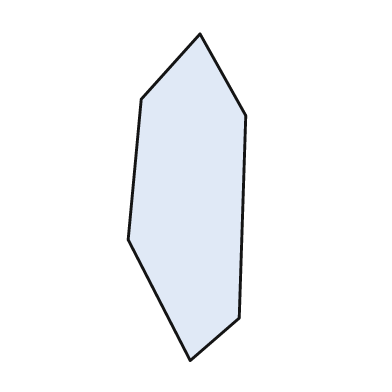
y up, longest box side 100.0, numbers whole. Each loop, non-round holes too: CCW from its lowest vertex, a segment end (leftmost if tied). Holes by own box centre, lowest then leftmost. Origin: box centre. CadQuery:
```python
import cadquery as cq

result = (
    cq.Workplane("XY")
    .moveTo(1.0, -50.0)
    .lineTo(16.0, -37.0)
    .lineTo(18.0, 25.0)
    .lineTo(4.0, 50.0)
    .lineTo(-14.0, 30.0)
    .lineTo(-18.0, -13.0)
    .close()
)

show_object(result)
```